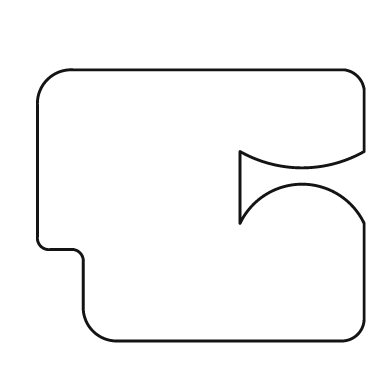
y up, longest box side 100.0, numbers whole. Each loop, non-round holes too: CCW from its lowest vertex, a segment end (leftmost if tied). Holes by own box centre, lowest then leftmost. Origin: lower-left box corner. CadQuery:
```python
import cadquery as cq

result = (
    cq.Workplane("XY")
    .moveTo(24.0, 0.0)
    .lineTo(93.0, 0.0)
    .threePointArc((98.0, 2.0), (100.0, 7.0))
    .lineTo(100.0, 36.0)
    .threePointArc((81.0, 48.0), (62.0, 36.0))
    .lineTo(62.0, 58.0)
    .threePointArc((81.0, 53.0), (100.0, 58.0))
    .lineTo(100.0, 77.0)
    .threePointArc((98.0, 81.0), (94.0, 83.0))
    .lineTo(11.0, 83.0)
    .threePointArc((3.0, 80.0), (0.0, 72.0))
    .lineTo(0.0, 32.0)
    .threePointArc((1.0, 29.0), (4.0, 28.0))
    .lineTo(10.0, 28.0)
    .threePointArc((13.0, 27.0), (14.0, 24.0))
    .lineTo(14.0, 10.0)
    .threePointArc((17.0, 3.0), (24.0, 0.0))
    .close()
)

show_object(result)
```